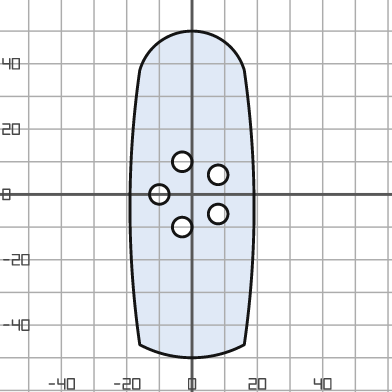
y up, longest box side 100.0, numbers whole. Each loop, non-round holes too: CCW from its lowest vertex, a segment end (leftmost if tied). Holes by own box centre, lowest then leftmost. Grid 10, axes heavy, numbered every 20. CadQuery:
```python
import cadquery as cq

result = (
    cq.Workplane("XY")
    .moveTo(-16.0, -46.0)
    .threePointArc((0.0, -50.0), (16.0, -46.0))
    .threePointArc((19.0, -4.0), (16.0, 38.0))
    .threePointArc((0.0, 50.0), (-16.0, 38.0))
    .threePointArc((-19.0, -4.0), (-16.0, -46.0))
    .close()
    .moveTo(-3.0, -10.0)
    .circle(3.0)
    .moveTo(8.0, -6.0)
    .circle(3.0)
    .moveTo(-10.0, 0.0)
    .circle(3.0)
    .moveTo(8.0, 6.0)
    .circle(3.0)
    .moveTo(-3.0, 10.0)
    .circle(3.0)
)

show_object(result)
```